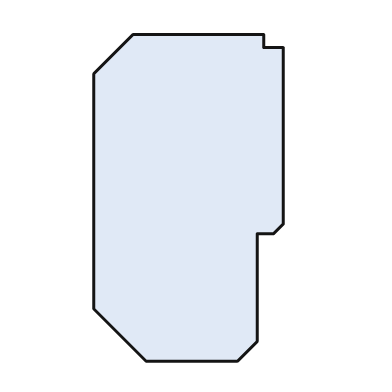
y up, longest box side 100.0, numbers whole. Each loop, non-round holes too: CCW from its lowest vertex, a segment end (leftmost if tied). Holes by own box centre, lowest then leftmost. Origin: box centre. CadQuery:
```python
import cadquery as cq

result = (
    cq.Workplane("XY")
    .moveTo(-13.0, -50.0)
    .lineTo(15.0, -50.0)
    .lineTo(21.0, -44.0)
    .lineTo(21.0, -11.0)
    .lineTo(26.0, -11.0)
    .lineTo(29.0, -8.0)
    .lineTo(29.0, 46.0)
    .lineTo(23.0, 46.0)
    .lineTo(23.0, 50.0)
    .lineTo(-17.0, 50.0)
    .lineTo(-29.0, 38.0)
    .lineTo(-29.0, -34.0)
    .close()
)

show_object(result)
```